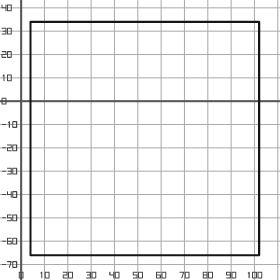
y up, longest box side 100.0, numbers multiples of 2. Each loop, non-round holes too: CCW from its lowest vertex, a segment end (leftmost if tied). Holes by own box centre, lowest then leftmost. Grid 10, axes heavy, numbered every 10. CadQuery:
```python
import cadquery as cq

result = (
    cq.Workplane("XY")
    .moveTo(4.0, -66.0)
    .lineTo(102.0, -66.0)
    .lineTo(102.0, 34.0)
    .lineTo(4.0, 34.0)
    .close()
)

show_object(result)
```